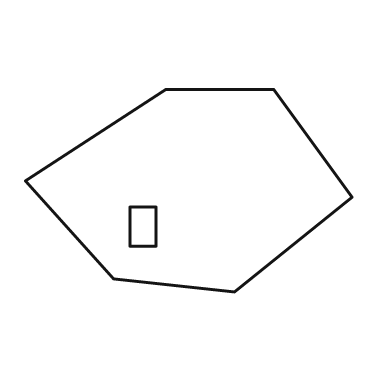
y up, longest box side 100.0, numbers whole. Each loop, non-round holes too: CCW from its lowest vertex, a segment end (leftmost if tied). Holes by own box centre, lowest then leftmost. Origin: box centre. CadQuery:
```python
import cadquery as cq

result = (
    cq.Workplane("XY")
    .moveTo(14.0, -31.0)
    .lineTo(50.0, -2.0)
    .lineTo(26.0, 31.0)
    .lineTo(-7.0, 31.0)
    .lineTo(-50.0, 3.0)
    .lineTo(-23.0, -27.0)
    .close()
    .moveTo(-18.0, -17.0)
    .lineTo(-10.0, -17.0)
    .lineTo(-10.0, -5.0)
    .lineTo(-18.0, -5.0)
    .close()
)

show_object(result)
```